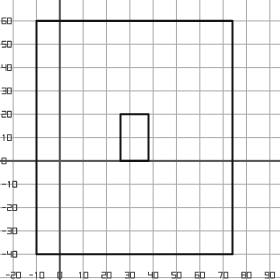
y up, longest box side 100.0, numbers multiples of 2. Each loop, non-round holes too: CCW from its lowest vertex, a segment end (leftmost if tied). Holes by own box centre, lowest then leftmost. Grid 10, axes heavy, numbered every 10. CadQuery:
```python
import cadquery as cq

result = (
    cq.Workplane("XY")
    .moveTo(-10.0, -40.0)
    .lineTo(74.0, -40.0)
    .lineTo(74.0, 60.0)
    .lineTo(-10.0, 60.0)
    .close()
    .moveTo(26.0, 0.0)
    .lineTo(38.0, 0.0)
    .lineTo(38.0, 20.0)
    .lineTo(26.0, 20.0)
    .close()
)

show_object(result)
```